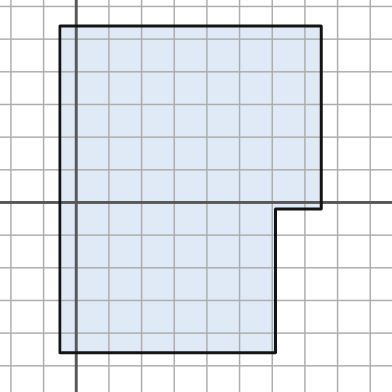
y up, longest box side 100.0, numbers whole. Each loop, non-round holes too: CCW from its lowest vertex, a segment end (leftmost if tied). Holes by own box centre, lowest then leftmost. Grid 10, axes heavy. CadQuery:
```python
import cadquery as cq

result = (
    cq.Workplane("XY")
    .moveTo(-5.0, -46.0)
    .lineTo(61.0, -46.0)
    .lineTo(61.0, -2.0)
    .lineTo(75.0, -2.0)
    .lineTo(75.0, 54.0)
    .lineTo(-5.0, 54.0)
    .close()
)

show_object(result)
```